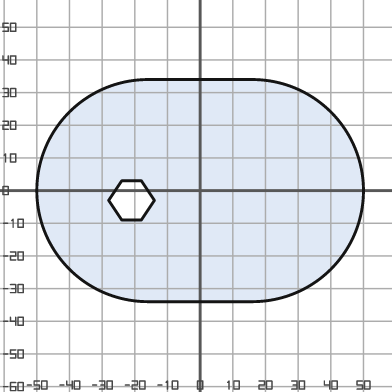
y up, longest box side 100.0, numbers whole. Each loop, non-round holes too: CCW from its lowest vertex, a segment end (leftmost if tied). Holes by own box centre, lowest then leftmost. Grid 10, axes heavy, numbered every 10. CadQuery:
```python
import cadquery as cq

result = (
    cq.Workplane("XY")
    .moveTo(-16.0, -34.0)
    .lineTo(16.0, -34.0)
    .threePointArc((50.0, 0.0), (16.0, 34.0))
    .lineTo(-16.0, 34.0)
    .threePointArc((-50.0, 0.0), (-16.0, -34.0))
    .close()
    .moveTo(-24.0, -9.0)
    .lineTo(-18.0, -9.0)
    .lineTo(-14.0, -3.0)
    .lineTo(-18.0, 3.0)
    .lineTo(-24.0, 3.0)
    .lineTo(-28.0, -3.0)
    .close()
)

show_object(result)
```